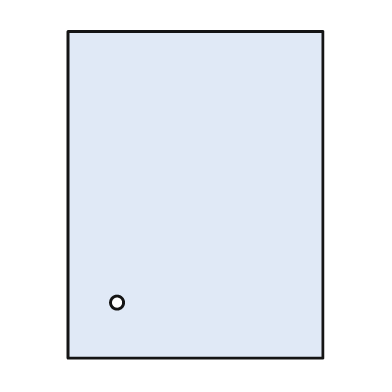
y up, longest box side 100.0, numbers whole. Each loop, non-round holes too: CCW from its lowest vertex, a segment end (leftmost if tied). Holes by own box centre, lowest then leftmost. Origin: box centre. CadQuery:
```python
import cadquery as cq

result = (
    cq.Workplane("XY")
    .moveTo(-39.0, -50.0)
    .lineTo(39.0, -50.0)
    .lineTo(39.0, 50.0)
    .lineTo(-39.0, 50.0)
    .close()
    .moveTo(-24.0, -33.0)
    .circle(2.0)
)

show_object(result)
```